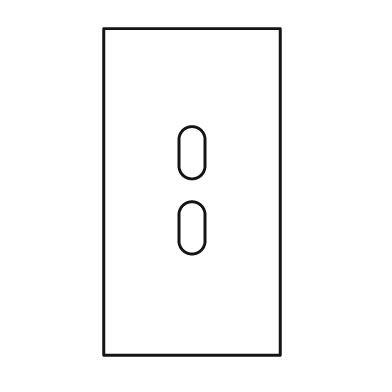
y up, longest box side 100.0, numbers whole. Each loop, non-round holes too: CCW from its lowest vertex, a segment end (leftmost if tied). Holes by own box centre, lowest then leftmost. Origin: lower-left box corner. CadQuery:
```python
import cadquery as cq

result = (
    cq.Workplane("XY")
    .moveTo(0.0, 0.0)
    .lineTo(54.0, 0.0)
    .lineTo(54.0, 100.0)
    .lineTo(0.0, 100.0)
    .close()
    .moveTo(23.0, 35.0)
    .threePointArc((27.0, 31.0), (31.0, 35.0))
    .lineTo(31.0, 43.0)
    .threePointArc((27.0, 47.0), (23.0, 43.0))
    .close()
    .moveTo(23.0, 58.0)
    .threePointArc((27.0, 54.0), (31.0, 58.0))
    .lineTo(31.0, 66.0)
    .threePointArc((27.0, 70.0), (23.0, 66.0))
    .close()
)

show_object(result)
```